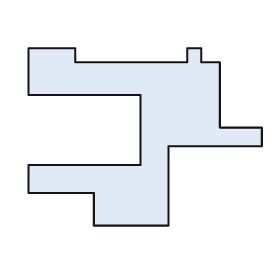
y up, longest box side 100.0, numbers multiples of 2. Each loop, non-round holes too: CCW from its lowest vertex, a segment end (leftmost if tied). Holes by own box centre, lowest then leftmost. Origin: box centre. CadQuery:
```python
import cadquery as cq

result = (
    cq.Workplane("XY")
    .moveTo(-22.0, -38.0)
    .lineTo(10.0, -38.0)
    .lineTo(10.0, -4.0)
    .lineTo(50.0, -4.0)
    .lineTo(50.0, 4.0)
    .lineTo(32.0, 4.0)
    .lineTo(32.0, 32.0)
    .lineTo(24.0, 32.0)
    .lineTo(24.0, 38.0)
    .lineTo(18.0, 38.0)
    .lineTo(18.0, 32.0)
    .lineTo(-30.0, 32.0)
    .lineTo(-30.0, 38.0)
    .lineTo(-50.0, 38.0)
    .lineTo(-50.0, 18.0)
    .lineTo(-2.0, 18.0)
    .lineTo(-2.0, -12.0)
    .lineTo(-50.0, -12.0)
    .lineTo(-50.0, -24.0)
    .lineTo(-22.0, -24.0)
    .close()
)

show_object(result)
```